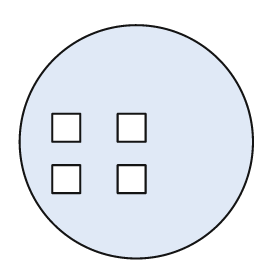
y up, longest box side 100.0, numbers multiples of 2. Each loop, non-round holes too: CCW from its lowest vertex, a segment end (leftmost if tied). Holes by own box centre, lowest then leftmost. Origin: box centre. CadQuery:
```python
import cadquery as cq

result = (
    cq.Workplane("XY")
    .moveTo(0.0, 0.0)
    .circle(50.0)
    .moveTo(-36.0, -22.0)
    .lineTo(-24.0, -22.0)
    .lineTo(-24.0, -10.0)
    .lineTo(-36.0, -10.0)
    .close()
    .moveTo(-8.0, -22.0)
    .lineTo(4.0, -22.0)
    .lineTo(4.0, -10.0)
    .lineTo(-8.0, -10.0)
    .close()
    .moveTo(-36.0, 0.0)
    .lineTo(-24.0, 0.0)
    .lineTo(-24.0, 12.0)
    .lineTo(-36.0, 12.0)
    .close()
    .moveTo(-8.0, 0.0)
    .lineTo(4.0, 0.0)
    .lineTo(4.0, 12.0)
    .lineTo(-8.0, 12.0)
    .close()
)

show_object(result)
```